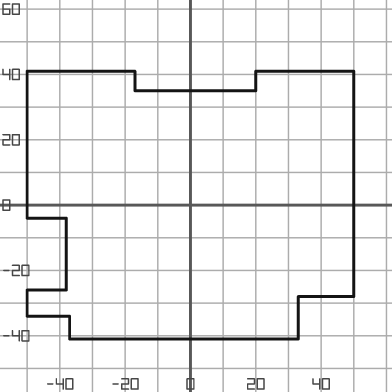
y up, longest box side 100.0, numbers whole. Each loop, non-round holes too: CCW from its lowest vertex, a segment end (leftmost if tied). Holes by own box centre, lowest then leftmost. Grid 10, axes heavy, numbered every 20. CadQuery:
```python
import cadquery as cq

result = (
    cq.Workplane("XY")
    .moveTo(-37.0, -41.0)
    .lineTo(33.0, -41.0)
    .lineTo(33.0, -28.0)
    .lineTo(50.0, -28.0)
    .lineTo(50.0, 41.0)
    .lineTo(20.0, 41.0)
    .lineTo(20.0, 35.0)
    .lineTo(-17.0, 35.0)
    .lineTo(-17.0, 41.0)
    .lineTo(-50.0, 41.0)
    .lineTo(-50.0, -4.0)
    .lineTo(-38.0, -4.0)
    .lineTo(-38.0, -26.0)
    .lineTo(-50.0, -26.0)
    .lineTo(-50.0, -34.0)
    .lineTo(-37.0, -34.0)
    .close()
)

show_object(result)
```